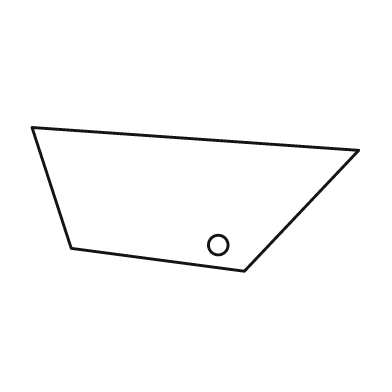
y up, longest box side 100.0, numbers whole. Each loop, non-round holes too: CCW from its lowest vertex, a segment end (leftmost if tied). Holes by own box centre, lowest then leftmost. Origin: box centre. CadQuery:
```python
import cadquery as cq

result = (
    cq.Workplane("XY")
    .moveTo(15.0, -22.0)
    .lineTo(50.0, 15.0)
    .lineTo(-50.0, 22.0)
    .lineTo(-38.0, -15.0)
    .close()
    .moveTo(7.0, -14.0)
    .circle(3.0)
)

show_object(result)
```